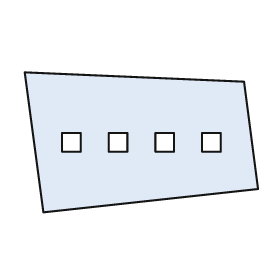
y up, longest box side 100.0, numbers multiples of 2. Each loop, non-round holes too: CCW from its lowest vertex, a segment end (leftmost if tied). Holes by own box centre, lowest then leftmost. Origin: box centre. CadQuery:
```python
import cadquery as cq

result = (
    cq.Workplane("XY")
    .moveTo(-42.0, -30.0)
    .lineTo(50.0, -20.0)
    .lineTo(44.0, 26.0)
    .lineTo(-50.0, 30.0)
    .close()
    .moveTo(-34.0, -4.0)
    .lineTo(-26.0, -4.0)
    .lineTo(-26.0, 4.0)
    .lineTo(-34.0, 4.0)
    .close()
    .moveTo(-14.0, -4.0)
    .lineTo(-6.0, -4.0)
    .lineTo(-6.0, 4.0)
    .lineTo(-14.0, 4.0)
    .close()
    .moveTo(6.0, -4.0)
    .lineTo(14.0, -4.0)
    .lineTo(14.0, 4.0)
    .lineTo(6.0, 4.0)
    .close()
    .moveTo(26.0, -4.0)
    .lineTo(34.0, -4.0)
    .lineTo(34.0, 4.0)
    .lineTo(26.0, 4.0)
    .close()
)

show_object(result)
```